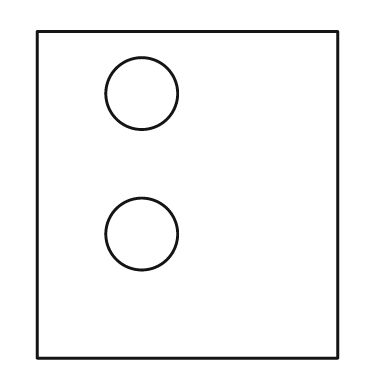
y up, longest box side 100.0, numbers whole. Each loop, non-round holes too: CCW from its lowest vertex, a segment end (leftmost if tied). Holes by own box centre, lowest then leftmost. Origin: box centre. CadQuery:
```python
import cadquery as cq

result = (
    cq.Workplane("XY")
    .moveTo(-46.0, -50.0)
    .lineTo(46.0, -50.0)
    .lineTo(46.0, 50.0)
    .lineTo(-46.0, 50.0)
    .close()
    .moveTo(-14.0, -12.0)
    .circle(11.0)
    .moveTo(-14.0, 31.0)
    .circle(11.0)
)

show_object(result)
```